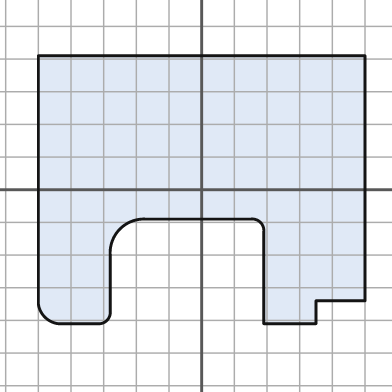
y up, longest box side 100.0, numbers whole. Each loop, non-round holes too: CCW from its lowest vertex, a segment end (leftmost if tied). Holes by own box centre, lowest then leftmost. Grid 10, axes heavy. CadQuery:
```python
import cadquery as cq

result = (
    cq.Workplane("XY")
    .moveTo(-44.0, -41.0)
    .lineTo(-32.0, -41.0)
    .threePointArc((-29.0, -40.0), (-28.0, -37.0))
    .lineTo(-28.0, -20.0)
    .threePointArc((-25.0, -12.0), (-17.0, -9.0))
    .lineTo(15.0, -9.0)
    .threePointArc((18.0, -10.0), (19.0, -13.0))
    .lineTo(19.0, -41.0)
    .lineTo(35.0, -41.0)
    .lineTo(35.0, -34.0)
    .lineTo(50.0, -34.0)
    .lineTo(50.0, 41.0)
    .lineTo(-50.0, 41.0)
    .lineTo(-50.0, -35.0)
    .threePointArc((-48.0, -39.0), (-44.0, -41.0))
    .close()
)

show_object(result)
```